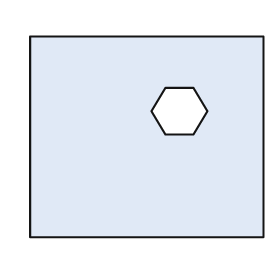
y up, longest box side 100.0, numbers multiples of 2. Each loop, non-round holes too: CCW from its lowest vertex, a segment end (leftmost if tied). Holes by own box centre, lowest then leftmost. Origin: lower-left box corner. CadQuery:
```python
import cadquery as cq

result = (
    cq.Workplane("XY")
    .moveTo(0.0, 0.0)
    .lineTo(100.0, 0.0)
    .lineTo(100.0, 86.0)
    .lineTo(0.0, 86.0)
    .close()
    .moveTo(58.0, 44.0)
    .lineTo(70.0, 44.0)
    .lineTo(76.0, 54.0)
    .lineTo(70.0, 64.0)
    .lineTo(58.0, 64.0)
    .lineTo(52.0, 54.0)
    .close()
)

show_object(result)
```